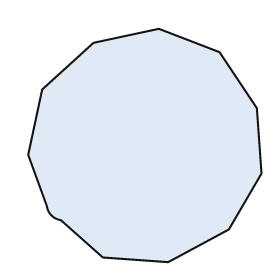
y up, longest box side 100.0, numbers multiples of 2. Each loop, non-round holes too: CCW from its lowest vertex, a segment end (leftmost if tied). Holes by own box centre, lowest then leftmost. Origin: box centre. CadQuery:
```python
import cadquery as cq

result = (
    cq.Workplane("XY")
    .moveTo(10.0, -50.0)
    .lineTo(36.0, -36.0)
    .lineTo(50.0, -12.0)
    .lineTo(48.0, 16.0)
    .lineTo(32.0, 40.0)
    .lineTo(6.0, 50.0)
    .lineTo(-22.0, 44.0)
    .lineTo(-44.0, 24.0)
    .lineTo(-50.0, -4.0)
    .lineTo(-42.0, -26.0)
    .threePointArc((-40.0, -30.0), (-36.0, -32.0))
    .lineTo(-18.0, -48.0)
    .close()
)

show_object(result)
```